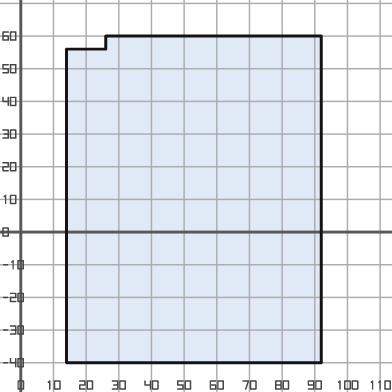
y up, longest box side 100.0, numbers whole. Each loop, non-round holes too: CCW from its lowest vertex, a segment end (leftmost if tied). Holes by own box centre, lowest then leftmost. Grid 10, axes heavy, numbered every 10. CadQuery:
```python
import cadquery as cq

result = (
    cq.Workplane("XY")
    .moveTo(14.0, -40.0)
    .lineTo(92.0, -40.0)
    .lineTo(92.0, 60.0)
    .lineTo(26.0, 60.0)
    .lineTo(26.0, 56.0)
    .lineTo(14.0, 56.0)
    .close()
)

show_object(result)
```